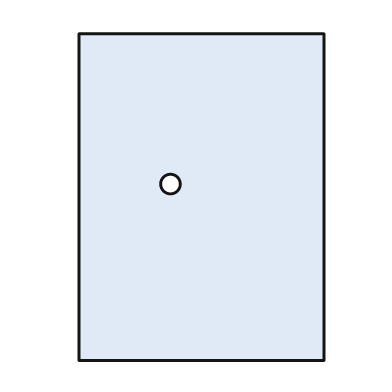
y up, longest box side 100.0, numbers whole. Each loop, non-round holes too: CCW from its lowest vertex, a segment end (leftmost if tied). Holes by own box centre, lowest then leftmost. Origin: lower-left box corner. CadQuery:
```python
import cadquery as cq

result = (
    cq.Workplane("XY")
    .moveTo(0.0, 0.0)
    .lineTo(75.0, 0.0)
    .lineTo(75.0, 100.0)
    .lineTo(0.0, 100.0)
    .close()
    .moveTo(28.0, 54.0)
    .circle(3.0)
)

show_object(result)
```